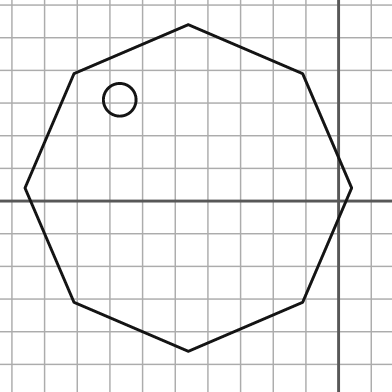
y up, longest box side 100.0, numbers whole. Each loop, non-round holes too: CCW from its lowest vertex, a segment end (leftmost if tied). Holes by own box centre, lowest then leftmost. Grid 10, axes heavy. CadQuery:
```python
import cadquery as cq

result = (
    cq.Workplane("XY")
    .moveTo(-46.0, -46.0)
    .lineTo(-11.0, -31.0)
    .lineTo(4.0, 4.0)
    .lineTo(-11.0, 39.0)
    .lineTo(-46.0, 54.0)
    .lineTo(-81.0, 39.0)
    .lineTo(-96.0, 4.0)
    .lineTo(-81.0, -31.0)
    .close()
    .moveTo(-67.0, 31.0)
    .circle(5.0)
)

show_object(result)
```